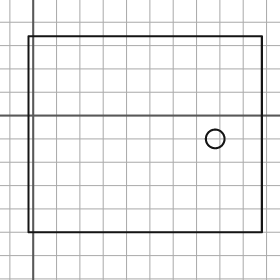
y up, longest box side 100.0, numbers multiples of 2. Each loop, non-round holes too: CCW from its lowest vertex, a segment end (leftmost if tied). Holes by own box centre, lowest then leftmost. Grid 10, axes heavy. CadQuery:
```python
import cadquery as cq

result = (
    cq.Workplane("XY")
    .moveTo(-2.0, -50.0)
    .lineTo(98.0, -50.0)
    .lineTo(98.0, 34.0)
    .lineTo(-2.0, 34.0)
    .close()
    .moveTo(78.0, -10.0)
    .circle(4.0)
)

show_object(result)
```